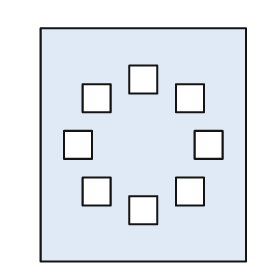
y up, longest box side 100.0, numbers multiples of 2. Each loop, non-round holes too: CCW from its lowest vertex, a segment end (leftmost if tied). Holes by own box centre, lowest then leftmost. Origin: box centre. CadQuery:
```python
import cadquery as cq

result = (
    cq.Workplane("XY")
    .moveTo(-44.0, -50.0)
    .lineTo(44.0, -50.0)
    .lineTo(44.0, 50.0)
    .lineTo(-44.0, 50.0)
    .close()
    .moveTo(-6.0, -34.0)
    .lineTo(6.0, -34.0)
    .lineTo(6.0, -22.0)
    .lineTo(-6.0, -22.0)
    .close()
    .moveTo(-26.0, -26.0)
    .lineTo(-14.0, -26.0)
    .lineTo(-14.0, -14.0)
    .lineTo(-26.0, -14.0)
    .close()
    .moveTo(14.0, -26.0)
    .lineTo(26.0, -26.0)
    .lineTo(26.0, -14.0)
    .lineTo(14.0, -14.0)
    .close()
    .moveTo(-34.0, -6.0)
    .lineTo(-22.0, -6.0)
    .lineTo(-22.0, 6.0)
    .lineTo(-34.0, 6.0)
    .close()
    .moveTo(22.0, -6.0)
    .lineTo(34.0, -6.0)
    .lineTo(34.0, 6.0)
    .lineTo(22.0, 6.0)
    .close()
    .moveTo(-26.0, 14.0)
    .lineTo(-14.0, 14.0)
    .lineTo(-14.0, 26.0)
    .lineTo(-26.0, 26.0)
    .close()
    .moveTo(14.0, 14.0)
    .lineTo(26.0, 14.0)
    .lineTo(26.0, 26.0)
    .lineTo(14.0, 26.0)
    .close()
    .moveTo(-6.0, 22.0)
    .lineTo(6.0, 22.0)
    .lineTo(6.0, 34.0)
    .lineTo(-6.0, 34.0)
    .close()
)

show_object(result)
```